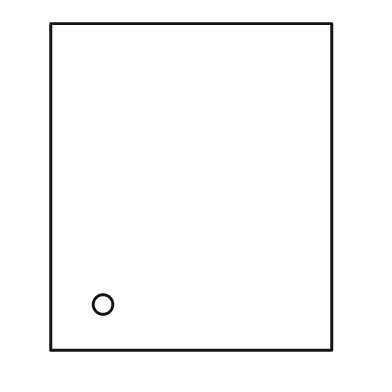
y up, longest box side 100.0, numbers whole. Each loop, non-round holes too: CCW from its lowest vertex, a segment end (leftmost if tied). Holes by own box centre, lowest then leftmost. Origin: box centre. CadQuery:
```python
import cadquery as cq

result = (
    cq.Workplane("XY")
    .moveTo(-43.0, -50.0)
    .lineTo(43.0, -50.0)
    .lineTo(43.0, 50.0)
    .lineTo(-43.0, 50.0)
    .close()
    .moveTo(-27.0, -36.0)
    .circle(3.0)
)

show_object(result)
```